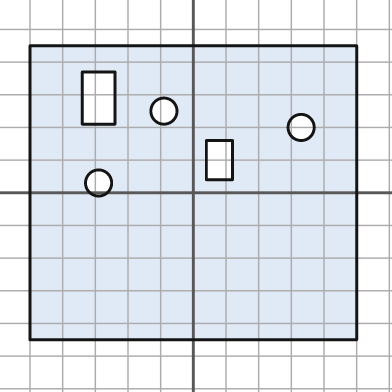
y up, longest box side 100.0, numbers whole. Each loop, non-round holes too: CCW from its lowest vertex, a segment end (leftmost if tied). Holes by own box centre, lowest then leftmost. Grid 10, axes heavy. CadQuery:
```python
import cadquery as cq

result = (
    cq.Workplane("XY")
    .moveTo(-50.0, -45.0)
    .lineTo(50.0, -45.0)
    .lineTo(50.0, 45.0)
    .lineTo(-50.0, 45.0)
    .close()
    .moveTo(-29.0, 3.0)
    .circle(4.0)
    .moveTo(4.0, 4.0)
    .lineTo(12.0, 4.0)
    .lineTo(12.0, 16.0)
    .lineTo(4.0, 16.0)
    .close()
    .moveTo(33.0, 20.0)
    .circle(4.0)
    .moveTo(-9.0, 25.0)
    .circle(4.0)
    .moveTo(-34.0, 21.0)
    .lineTo(-24.0, 21.0)
    .lineTo(-24.0, 37.0)
    .lineTo(-34.0, 37.0)
    .close()
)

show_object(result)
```